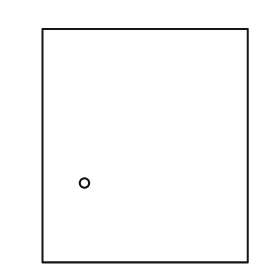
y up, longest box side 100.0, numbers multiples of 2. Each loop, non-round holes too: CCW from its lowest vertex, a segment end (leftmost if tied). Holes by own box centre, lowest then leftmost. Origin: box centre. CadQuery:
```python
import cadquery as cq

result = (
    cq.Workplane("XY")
    .moveTo(-44.0, -50.0)
    .lineTo(44.0, -50.0)
    .lineTo(44.0, 50.0)
    .lineTo(-44.0, 50.0)
    .close()
    .moveTo(-26.0, -16.0)
    .circle(2.0)
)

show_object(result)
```